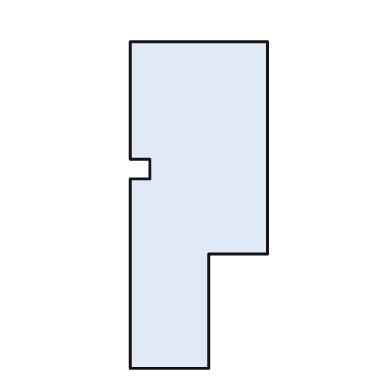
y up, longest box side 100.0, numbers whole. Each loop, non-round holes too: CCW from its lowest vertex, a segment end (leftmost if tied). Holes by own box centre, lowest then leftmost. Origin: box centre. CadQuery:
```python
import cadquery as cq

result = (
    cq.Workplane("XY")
    .moveTo(-21.0, -50.0)
    .lineTo(3.0, -50.0)
    .lineTo(3.0, -15.0)
    .lineTo(21.0, -15.0)
    .lineTo(21.0, 50.0)
    .lineTo(-21.0, 50.0)
    .lineTo(-21.0, 14.0)
    .lineTo(-15.0, 14.0)
    .lineTo(-15.0, 8.0)
    .lineTo(-21.0, 8.0)
    .close()
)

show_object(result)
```